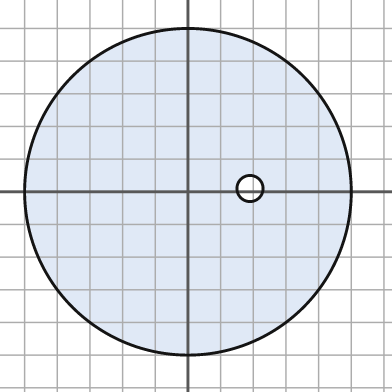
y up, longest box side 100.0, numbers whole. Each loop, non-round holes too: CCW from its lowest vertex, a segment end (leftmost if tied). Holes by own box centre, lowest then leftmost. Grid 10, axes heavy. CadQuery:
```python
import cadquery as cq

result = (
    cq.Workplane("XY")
    .moveTo(0.0, 0.0)
    .circle(50.0)
    .moveTo(19.0, 1.0)
    .circle(4.0)
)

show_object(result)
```